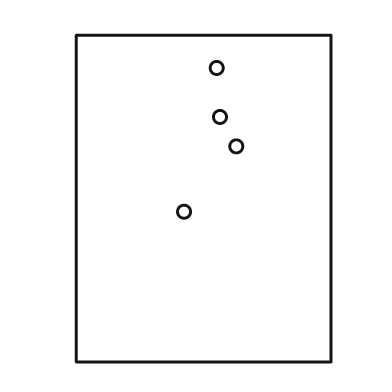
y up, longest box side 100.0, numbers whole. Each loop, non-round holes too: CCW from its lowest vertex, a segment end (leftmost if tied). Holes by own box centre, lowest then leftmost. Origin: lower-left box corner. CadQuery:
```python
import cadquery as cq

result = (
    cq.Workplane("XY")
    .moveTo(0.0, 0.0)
    .lineTo(78.0, 0.0)
    .lineTo(78.0, 100.0)
    .lineTo(0.0, 100.0)
    .close()
    .moveTo(33.0, 46.0)
    .circle(2.0)
    .moveTo(49.0, 66.0)
    .circle(2.0)
    .moveTo(44.0, 75.0)
    .circle(2.0)
    .moveTo(43.0, 90.0)
    .circle(2.0)
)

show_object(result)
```